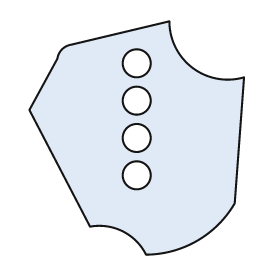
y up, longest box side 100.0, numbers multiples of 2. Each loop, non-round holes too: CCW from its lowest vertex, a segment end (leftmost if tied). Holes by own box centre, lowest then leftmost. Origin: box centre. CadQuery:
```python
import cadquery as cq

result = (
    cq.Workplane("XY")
    .moveTo(4.0, -50.0)
    .threePointArc((26.0, -44.0), (42.0, -28.0))
    .lineTo(46.0, 26.0)
    .threePointArc((24.0, 30.0), (14.0, 50.0))
    .lineTo(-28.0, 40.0)
    .threePointArc((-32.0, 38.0), (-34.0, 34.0))
    .lineTo(-46.0, 12.0)
    .lineTo(-20.0, -38.0)
    .threePointArc((-6.0, -40.0), (4.0, -50.0))
    .close()
    .moveTo(0.0, -16.0)
    .circle(6.0)
    .moveTo(0.0, 0.0)
    .circle(6.0)
    .moveTo(0.0, 16.0)
    .circle(6.0)
    .moveTo(0.0, 32.0)
    .circle(6.0)
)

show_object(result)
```